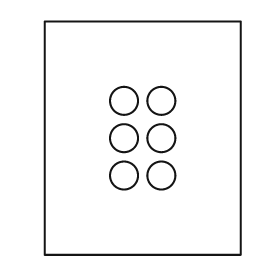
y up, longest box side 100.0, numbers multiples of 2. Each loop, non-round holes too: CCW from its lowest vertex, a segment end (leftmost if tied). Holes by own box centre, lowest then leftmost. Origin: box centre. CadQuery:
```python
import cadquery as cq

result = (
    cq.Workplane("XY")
    .moveTo(-42.0, -50.0)
    .lineTo(42.0, -50.0)
    .lineTo(42.0, 50.0)
    .lineTo(-42.0, 50.0)
    .close()
    .moveTo(-8.0, -16.0)
    .circle(6.0)
    .moveTo(8.0, -16.0)
    .circle(6.0)
    .moveTo(-8.0, 0.0)
    .circle(6.0)
    .moveTo(8.0, 0.0)
    .circle(6.0)
    .moveTo(-8.0, 16.0)
    .circle(6.0)
    .moveTo(8.0, 16.0)
    .circle(6.0)
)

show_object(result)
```